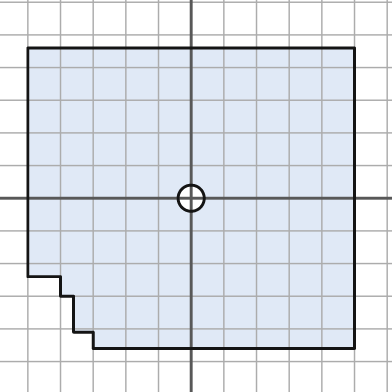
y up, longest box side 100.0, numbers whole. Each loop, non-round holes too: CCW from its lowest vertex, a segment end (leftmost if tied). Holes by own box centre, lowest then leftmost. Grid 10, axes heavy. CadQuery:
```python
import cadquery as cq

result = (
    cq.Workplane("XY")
    .moveTo(-30.0, -46.0)
    .lineTo(50.0, -46.0)
    .lineTo(50.0, 46.0)
    .lineTo(-50.0, 46.0)
    .lineTo(-50.0, -24.0)
    .lineTo(-40.0, -24.0)
    .lineTo(-40.0, -30.0)
    .lineTo(-36.0, -30.0)
    .lineTo(-36.0, -41.0)
    .lineTo(-30.0, -41.0)
    .close()
    .moveTo(0.0, 0.0)
    .circle(4.0)
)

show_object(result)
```